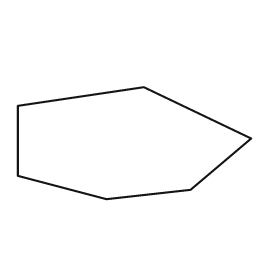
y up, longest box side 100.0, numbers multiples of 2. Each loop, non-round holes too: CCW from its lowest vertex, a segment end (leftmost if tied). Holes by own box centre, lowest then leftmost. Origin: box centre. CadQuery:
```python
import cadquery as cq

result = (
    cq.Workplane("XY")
    .moveTo(-12.0, -24.0)
    .lineTo(24.0, -20.0)
    .lineTo(50.0, 2.0)
    .lineTo(4.0, 24.0)
    .lineTo(-50.0, 16.0)
    .lineTo(-50.0, -14.0)
    .close()
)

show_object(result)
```